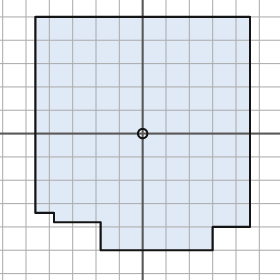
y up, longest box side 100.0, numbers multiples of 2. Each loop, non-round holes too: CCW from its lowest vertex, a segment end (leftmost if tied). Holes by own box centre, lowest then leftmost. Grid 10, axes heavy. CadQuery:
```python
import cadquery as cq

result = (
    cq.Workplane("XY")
    .moveTo(-18.0, -50.0)
    .lineTo(30.0, -50.0)
    .lineTo(30.0, -40.0)
    .lineTo(46.0, -40.0)
    .lineTo(46.0, 50.0)
    .lineTo(-46.0, 50.0)
    .lineTo(-46.0, -34.0)
    .lineTo(-38.0, -34.0)
    .lineTo(-38.0, -38.0)
    .lineTo(-18.0, -38.0)
    .close()
    .moveTo(0.0, 0.0)
    .circle(2.0)
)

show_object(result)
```